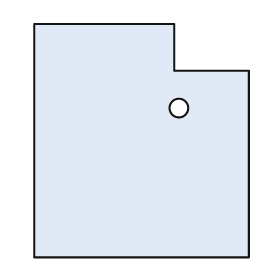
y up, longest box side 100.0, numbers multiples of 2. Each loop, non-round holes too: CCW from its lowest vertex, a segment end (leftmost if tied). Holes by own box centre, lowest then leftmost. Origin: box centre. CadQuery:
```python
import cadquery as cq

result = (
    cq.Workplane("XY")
    .moveTo(-46.0, -50.0)
    .lineTo(46.0, -50.0)
    .lineTo(46.0, 30.0)
    .lineTo(14.0, 30.0)
    .lineTo(14.0, 50.0)
    .lineTo(-46.0, 50.0)
    .close()
    .moveTo(16.0, 14.0)
    .circle(4.0)
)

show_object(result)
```